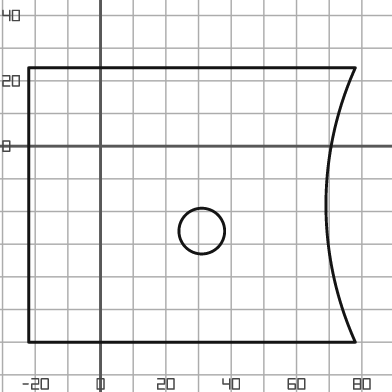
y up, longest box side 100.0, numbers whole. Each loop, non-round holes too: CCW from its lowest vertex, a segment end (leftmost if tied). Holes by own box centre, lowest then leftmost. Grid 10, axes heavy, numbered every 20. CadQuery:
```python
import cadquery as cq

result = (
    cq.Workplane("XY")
    .moveTo(-22.0, -60.0)
    .lineTo(78.0, -60.0)
    .threePointArc((69.0, -18.0), (78.0, 24.0))
    .lineTo(-22.0, 24.0)
    .close()
    .moveTo(31.0, -26.0)
    .circle(7.0)
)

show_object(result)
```